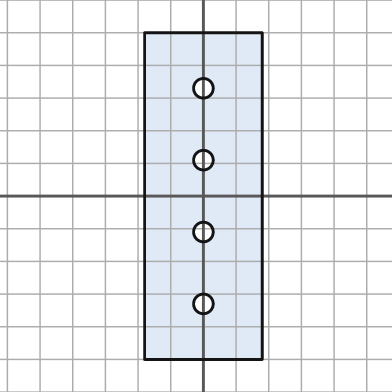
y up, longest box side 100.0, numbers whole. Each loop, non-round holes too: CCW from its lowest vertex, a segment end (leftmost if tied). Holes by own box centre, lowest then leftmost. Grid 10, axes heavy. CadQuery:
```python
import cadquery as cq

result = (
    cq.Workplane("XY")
    .moveTo(-18.0, -50.0)
    .lineTo(18.0, -50.0)
    .lineTo(18.0, 50.0)
    .lineTo(-18.0, 50.0)
    .close()
    .moveTo(0.0, -33.0)
    .circle(3.0)
    .moveTo(0.0, -11.0)
    .circle(3.0)
    .moveTo(0.0, 11.0)
    .circle(3.0)
    .moveTo(0.0, 33.0)
    .circle(3.0)
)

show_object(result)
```